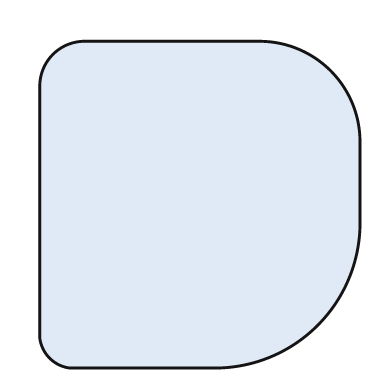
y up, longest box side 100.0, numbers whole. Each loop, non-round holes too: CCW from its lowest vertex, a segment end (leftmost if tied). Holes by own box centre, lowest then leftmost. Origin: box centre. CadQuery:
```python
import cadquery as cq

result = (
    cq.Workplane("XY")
    .moveTo(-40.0, -50.0)
    .lineTo(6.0, -50.0)
    .threePointArc((36.0, -37.0), (49.0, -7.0))
    .lineTo(49.0, 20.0)
    .threePointArc((40.0, 41.0), (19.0, 50.0))
    .lineTo(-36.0, 50.0)
    .threePointArc((-45.0, 46.0), (-49.0, 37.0))
    .lineTo(-49.0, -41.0)
    .threePointArc((-46.0, -47.0), (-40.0, -50.0))
    .close()
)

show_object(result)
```